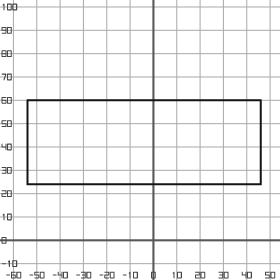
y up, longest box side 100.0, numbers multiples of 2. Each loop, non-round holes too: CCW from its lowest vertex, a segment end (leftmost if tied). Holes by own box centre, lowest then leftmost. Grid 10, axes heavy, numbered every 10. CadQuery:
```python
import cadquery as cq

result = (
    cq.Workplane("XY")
    .moveTo(-54.0, 24.0)
    .lineTo(46.0, 24.0)
    .lineTo(46.0, 60.0)
    .lineTo(-54.0, 60.0)
    .close()
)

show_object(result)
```